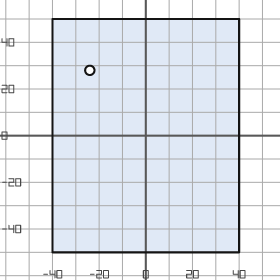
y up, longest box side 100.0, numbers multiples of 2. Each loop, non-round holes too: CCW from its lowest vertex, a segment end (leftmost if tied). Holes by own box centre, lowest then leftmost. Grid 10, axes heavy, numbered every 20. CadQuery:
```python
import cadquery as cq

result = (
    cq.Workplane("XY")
    .moveTo(-40.0, -50.0)
    .lineTo(40.0, -50.0)
    .lineTo(40.0, 50.0)
    .lineTo(-40.0, 50.0)
    .close()
    .moveTo(-24.0, 28.0)
    .circle(2.0)
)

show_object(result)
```